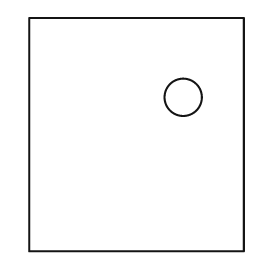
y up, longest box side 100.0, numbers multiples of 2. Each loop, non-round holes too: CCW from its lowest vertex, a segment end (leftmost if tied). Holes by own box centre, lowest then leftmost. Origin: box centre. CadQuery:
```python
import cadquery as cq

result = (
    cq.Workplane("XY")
    .moveTo(-46.0, -50.0)
    .lineTo(46.0, -50.0)
    .lineTo(46.0, 50.0)
    .lineTo(-46.0, 50.0)
    .close()
    .moveTo(20.0, 16.0)
    .circle(8.0)
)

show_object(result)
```